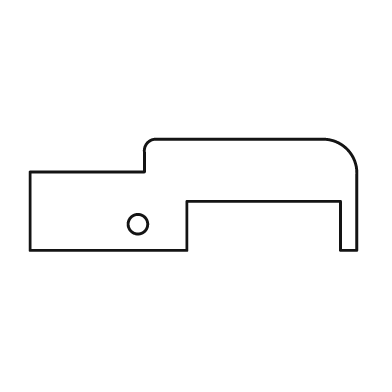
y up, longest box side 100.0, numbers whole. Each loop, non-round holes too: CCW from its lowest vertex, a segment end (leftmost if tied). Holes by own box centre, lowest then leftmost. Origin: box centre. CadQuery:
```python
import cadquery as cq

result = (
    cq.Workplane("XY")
    .moveTo(-50.0, -17.0)
    .lineTo(-2.0, -17.0)
    .lineTo(-2.0, -2.0)
    .lineTo(45.0, -2.0)
    .lineTo(45.0, -17.0)
    .lineTo(50.0, -17.0)
    .lineTo(50.0, 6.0)
    .threePointArc((47.0, 14.0), (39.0, 17.0))
    .lineTo(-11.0, 17.0)
    .threePointArc((-14.0, 16.0), (-15.0, 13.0))
    .lineTo(-15.0, 7.0)
    .lineTo(-50.0, 7.0)
    .close()
    .moveTo(-17.0, -9.0)
    .circle(3.0)
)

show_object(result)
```